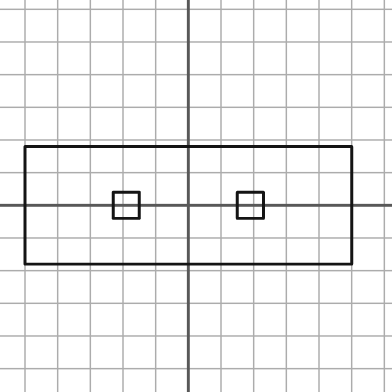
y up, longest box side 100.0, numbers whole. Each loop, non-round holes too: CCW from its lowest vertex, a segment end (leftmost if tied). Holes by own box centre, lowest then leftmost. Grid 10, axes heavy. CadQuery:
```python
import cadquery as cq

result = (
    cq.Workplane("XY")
    .moveTo(-50.0, -18.0)
    .lineTo(50.0, -18.0)
    .lineTo(50.0, 18.0)
    .lineTo(-50.0, 18.0)
    .close()
    .moveTo(-23.0, -4.0)
    .lineTo(-15.0, -4.0)
    .lineTo(-15.0, 4.0)
    .lineTo(-23.0, 4.0)
    .close()
    .moveTo(15.0, -4.0)
    .lineTo(23.0, -4.0)
    .lineTo(23.0, 4.0)
    .lineTo(15.0, 4.0)
    .close()
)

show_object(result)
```